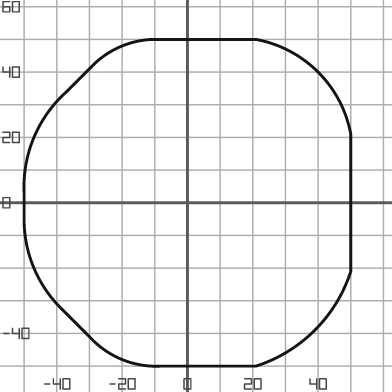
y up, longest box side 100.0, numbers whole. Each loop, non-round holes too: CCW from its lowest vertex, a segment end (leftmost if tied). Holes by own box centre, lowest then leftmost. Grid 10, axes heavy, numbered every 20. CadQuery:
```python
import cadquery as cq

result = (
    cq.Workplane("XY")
    .moveTo(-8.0, -50.0)
    .lineTo(21.0, -50.0)
    .threePointArc((39.0, -39.0), (50.0, -21.0))
    .lineTo(50.0, 21.0)
    .threePointArc((40.0, 40.0), (21.0, 50.0))
    .lineTo(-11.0, 50.0)
    .threePointArc((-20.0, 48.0), (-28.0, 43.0))
    .lineTo(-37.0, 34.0)
    .threePointArc((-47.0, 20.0), (-50.0, 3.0))
    .lineTo(-50.0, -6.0)
    .threePointArc((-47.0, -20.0), (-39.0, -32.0))
    .lineTo(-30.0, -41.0)
    .threePointArc((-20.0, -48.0), (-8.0, -50.0))
    .close()
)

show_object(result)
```